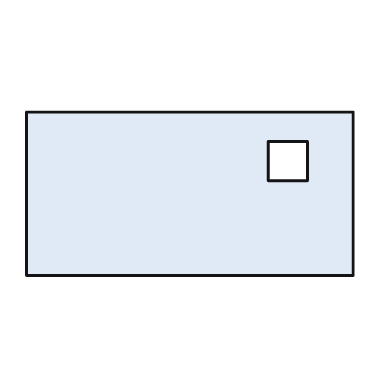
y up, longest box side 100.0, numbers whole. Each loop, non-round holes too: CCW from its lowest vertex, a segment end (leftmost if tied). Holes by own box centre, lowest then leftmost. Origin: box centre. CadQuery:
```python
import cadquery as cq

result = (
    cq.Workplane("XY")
    .moveTo(-50.0, -25.0)
    .lineTo(50.0, -25.0)
    .lineTo(50.0, 25.0)
    .lineTo(-50.0, 25.0)
    .close()
    .moveTo(24.0, 4.0)
    .lineTo(36.0, 4.0)
    .lineTo(36.0, 16.0)
    .lineTo(24.0, 16.0)
    .close()
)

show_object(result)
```